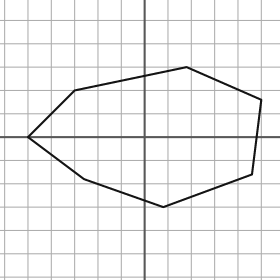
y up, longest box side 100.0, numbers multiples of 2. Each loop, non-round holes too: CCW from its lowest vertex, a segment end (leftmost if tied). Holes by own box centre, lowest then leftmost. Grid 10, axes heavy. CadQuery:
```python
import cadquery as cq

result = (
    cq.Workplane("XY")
    .moveTo(8.0, -30.0)
    .lineTo(46.0, -16.0)
    .lineTo(50.0, 16.0)
    .lineTo(18.0, 30.0)
    .lineTo(-30.0, 20.0)
    .lineTo(-50.0, 0.0)
    .lineTo(-26.0, -18.0)
    .close()
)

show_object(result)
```